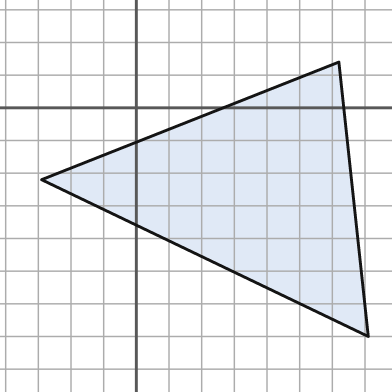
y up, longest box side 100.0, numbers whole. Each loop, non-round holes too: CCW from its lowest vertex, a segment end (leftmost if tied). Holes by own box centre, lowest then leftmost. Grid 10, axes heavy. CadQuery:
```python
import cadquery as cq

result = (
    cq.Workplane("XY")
    .moveTo(71.0, -70.0)
    .lineTo(62.0, 14.0)
    .lineTo(-29.0, -22.0)
    .close()
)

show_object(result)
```